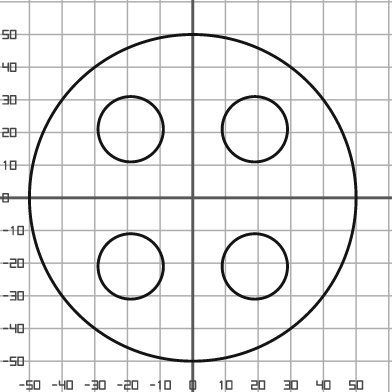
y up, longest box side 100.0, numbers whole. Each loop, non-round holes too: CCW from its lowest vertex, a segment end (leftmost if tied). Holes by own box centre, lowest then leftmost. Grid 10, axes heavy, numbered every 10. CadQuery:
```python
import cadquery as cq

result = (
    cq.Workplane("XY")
    .moveTo(0.0, 0.0)
    .circle(50.0)
    .moveTo(-19.0, -21.0)
    .circle(10.0)
    .moveTo(19.0, -21.0)
    .circle(10.0)
    .moveTo(-19.0, 21.0)
    .circle(10.0)
    .moveTo(19.0, 21.0)
    .circle(10.0)
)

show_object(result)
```